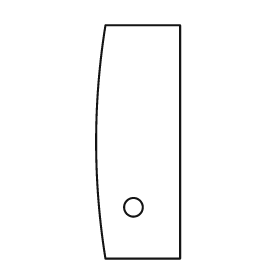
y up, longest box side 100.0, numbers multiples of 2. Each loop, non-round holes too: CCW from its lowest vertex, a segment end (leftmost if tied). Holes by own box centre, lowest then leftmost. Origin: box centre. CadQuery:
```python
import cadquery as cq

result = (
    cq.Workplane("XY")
    .moveTo(-14.0, -50.0)
    .lineTo(18.0, -50.0)
    .lineTo(18.0, 50.0)
    .lineTo(-14.0, 50.0)
    .threePointArc((-18.0, 0.0), (-14.0, -50.0))
    .close()
    .moveTo(-2.0, -28.0)
    .circle(4.0)
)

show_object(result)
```